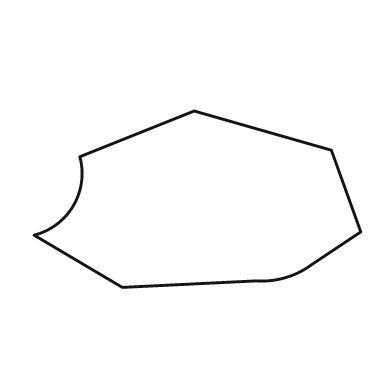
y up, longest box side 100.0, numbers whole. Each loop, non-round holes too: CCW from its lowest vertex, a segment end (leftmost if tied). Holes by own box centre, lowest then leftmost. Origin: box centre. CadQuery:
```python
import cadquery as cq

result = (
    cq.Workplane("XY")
    .moveTo(-23.0, -27.0)
    .lineTo(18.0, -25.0)
    .threePointArc((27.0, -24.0), (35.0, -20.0))
    .lineTo(50.0, -10.0)
    .lineTo(41.0, 15.0)
    .lineTo(-1.0, 27.0)
    .lineTo(-36.0, 13.0)
    .threePointArc((-38.0, -2.0), (-50.0, -11.0))
    .close()
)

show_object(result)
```